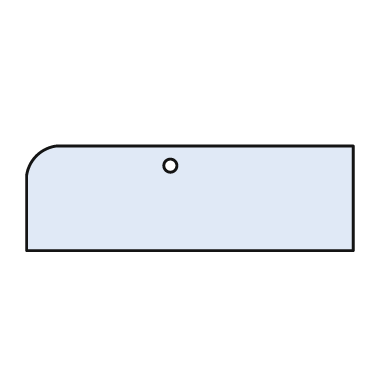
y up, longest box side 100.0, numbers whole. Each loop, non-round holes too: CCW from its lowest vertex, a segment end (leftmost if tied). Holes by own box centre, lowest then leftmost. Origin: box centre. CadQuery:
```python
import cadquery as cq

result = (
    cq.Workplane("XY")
    .moveTo(-50.0, -16.0)
    .lineTo(50.0, -16.0)
    .lineTo(50.0, 16.0)
    .lineTo(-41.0, 16.0)
    .threePointArc((-47.0, 13.0), (-50.0, 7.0))
    .close()
    .moveTo(-6.0, 10.0)
    .circle(2.0)
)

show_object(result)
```